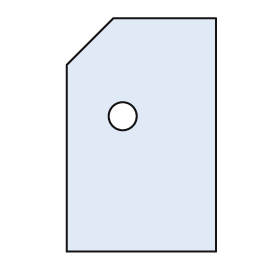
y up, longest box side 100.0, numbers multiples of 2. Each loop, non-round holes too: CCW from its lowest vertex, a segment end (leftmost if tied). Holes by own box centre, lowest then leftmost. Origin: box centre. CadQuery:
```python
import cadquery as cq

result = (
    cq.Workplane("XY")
    .moveTo(-32.0, -50.0)
    .lineTo(32.0, -50.0)
    .lineTo(32.0, 50.0)
    .lineTo(-12.0, 50.0)
    .lineTo(-32.0, 30.0)
    .close()
    .moveTo(-8.0, 8.0)
    .circle(6.0)
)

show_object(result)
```